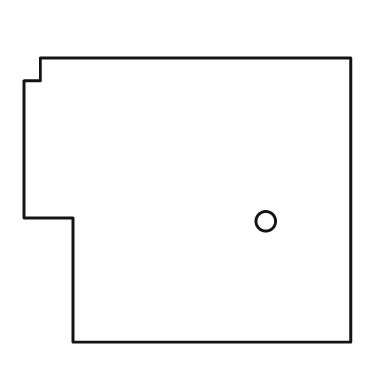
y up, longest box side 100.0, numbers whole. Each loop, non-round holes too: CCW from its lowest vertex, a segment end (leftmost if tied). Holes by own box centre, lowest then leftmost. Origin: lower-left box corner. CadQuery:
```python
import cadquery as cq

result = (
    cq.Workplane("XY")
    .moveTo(15.0, 0.0)
    .lineTo(100.0, 0.0)
    .lineTo(100.0, 87.0)
    .lineTo(5.0, 87.0)
    .lineTo(5.0, 80.0)
    .lineTo(0.0, 80.0)
    .lineTo(0.0, 38.0)
    .lineTo(15.0, 38.0)
    .close()
    .moveTo(74.0, 37.0)
    .circle(3.0)
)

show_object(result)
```